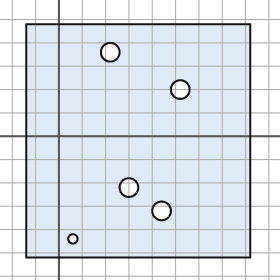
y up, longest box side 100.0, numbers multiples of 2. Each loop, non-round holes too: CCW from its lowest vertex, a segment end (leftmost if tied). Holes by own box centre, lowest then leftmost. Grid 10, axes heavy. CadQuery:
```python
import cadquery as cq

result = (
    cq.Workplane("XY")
    .moveTo(-14.0, -52.0)
    .lineTo(82.0, -52.0)
    .lineTo(82.0, 48.0)
    .lineTo(-14.0, 48.0)
    .close()
    .moveTo(6.0, -44.0)
    .circle(2.0)
    .moveTo(44.0, -32.0)
    .circle(4.0)
    .moveTo(30.0, -22.0)
    .circle(4.0)
    .moveTo(52.0, 20.0)
    .circle(4.0)
    .moveTo(22.0, 36.0)
    .circle(4.0)
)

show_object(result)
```